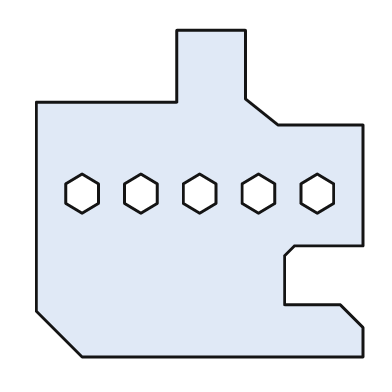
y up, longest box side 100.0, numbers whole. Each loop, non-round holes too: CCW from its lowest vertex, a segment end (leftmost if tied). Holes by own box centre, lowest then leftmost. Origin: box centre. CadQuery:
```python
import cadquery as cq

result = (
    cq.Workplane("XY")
    .moveTo(-36.0, -50.0)
    .lineTo(50.0, -50.0)
    .lineTo(50.0, -41.0)
    .lineTo(43.0, -34.0)
    .lineTo(26.0, -34.0)
    .lineTo(26.0, -19.0)
    .lineTo(29.0, -16.0)
    .lineTo(50.0, -16.0)
    .lineTo(50.0, 21.0)
    .lineTo(24.0, 21.0)
    .lineTo(14.0, 29.0)
    .lineTo(14.0, 50.0)
    .lineTo(-7.0, 50.0)
    .lineTo(-7.0, 28.0)
    .lineTo(-50.0, 28.0)
    .lineTo(-50.0, -36.0)
    .close()
    .moveTo(-36.0, -6.0)
    .lineTo(-31.0, -3.0)
    .lineTo(-31.0, 3.0)
    .lineTo(-36.0, 6.0)
    .lineTo(-41.0, 3.0)
    .lineTo(-41.0, -3.0)
    .close()
    .moveTo(-18.0, -6.0)
    .lineTo(-13.0, -3.0)
    .lineTo(-13.0, 3.0)
    .lineTo(-18.0, 6.0)
    .lineTo(-23.0, 3.0)
    .lineTo(-23.0, -3.0)
    .close()
    .moveTo(0.0, -6.0)
    .lineTo(5.0, -3.0)
    .lineTo(5.0, 3.0)
    .lineTo(0.0, 6.0)
    .lineTo(-5.0, 3.0)
    .lineTo(-5.0, -3.0)
    .close()
    .moveTo(18.0, -6.0)
    .lineTo(23.0, -3.0)
    .lineTo(23.0, 3.0)
    .lineTo(18.0, 6.0)
    .lineTo(13.0, 3.0)
    .lineTo(13.0, -3.0)
    .close()
    .moveTo(36.0, -6.0)
    .lineTo(41.0, -3.0)
    .lineTo(41.0, 3.0)
    .lineTo(36.0, 6.0)
    .lineTo(31.0, 3.0)
    .lineTo(31.0, -3.0)
    .close()
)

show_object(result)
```